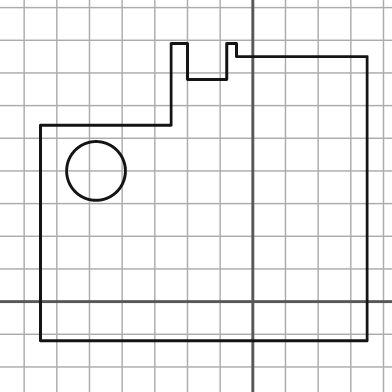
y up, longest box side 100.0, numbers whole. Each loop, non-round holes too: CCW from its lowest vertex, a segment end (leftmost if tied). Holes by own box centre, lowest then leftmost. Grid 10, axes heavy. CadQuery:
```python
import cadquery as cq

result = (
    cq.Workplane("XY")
    .moveTo(-65.0, -12.0)
    .lineTo(35.0, -12.0)
    .lineTo(35.0, 75.0)
    .lineTo(-5.0, 75.0)
    .lineTo(-5.0, 79.0)
    .lineTo(-8.0, 79.0)
    .lineTo(-8.0, 68.0)
    .lineTo(-20.0, 68.0)
    .lineTo(-20.0, 79.0)
    .lineTo(-25.0, 79.0)
    .lineTo(-25.0, 54.0)
    .lineTo(-65.0, 54.0)
    .close()
    .moveTo(-48.0, 40.0)
    .circle(9.0)
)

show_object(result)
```